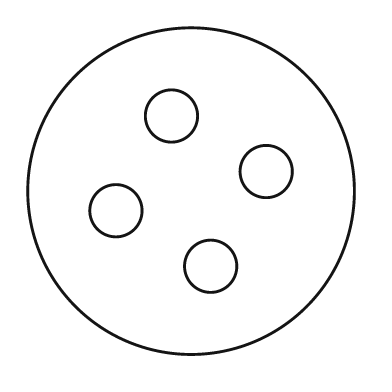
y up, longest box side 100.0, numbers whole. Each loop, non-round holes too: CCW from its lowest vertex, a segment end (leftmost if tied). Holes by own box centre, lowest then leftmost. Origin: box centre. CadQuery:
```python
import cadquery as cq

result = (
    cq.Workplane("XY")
    .moveTo(0.0, 0.0)
    .circle(50.0)
    .moveTo(6.0, -23.0)
    .circle(8.0)
    .moveTo(-23.0, -6.0)
    .circle(8.0)
    .moveTo(23.0, 6.0)
    .circle(8.0)
    .moveTo(-6.0, 23.0)
    .circle(8.0)
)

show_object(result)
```